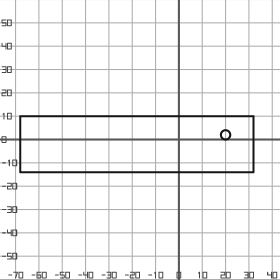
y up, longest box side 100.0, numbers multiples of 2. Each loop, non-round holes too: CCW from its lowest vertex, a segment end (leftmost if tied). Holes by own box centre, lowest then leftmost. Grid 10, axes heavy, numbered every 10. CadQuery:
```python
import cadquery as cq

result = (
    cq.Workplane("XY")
    .moveTo(-68.0, -14.0)
    .lineTo(32.0, -14.0)
    .lineTo(32.0, 10.0)
    .lineTo(-68.0, 10.0)
    .close()
    .moveTo(20.0, 2.0)
    .circle(2.0)
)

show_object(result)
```